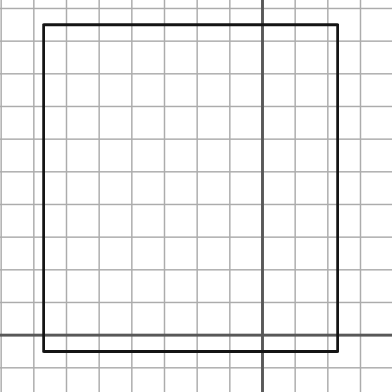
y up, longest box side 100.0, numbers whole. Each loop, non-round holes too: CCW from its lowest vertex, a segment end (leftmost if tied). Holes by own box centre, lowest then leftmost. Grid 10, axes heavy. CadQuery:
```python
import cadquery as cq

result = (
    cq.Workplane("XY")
    .moveTo(-67.0, -5.0)
    .lineTo(23.0, -5.0)
    .lineTo(23.0, 95.0)
    .lineTo(-67.0, 95.0)
    .close()
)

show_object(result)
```